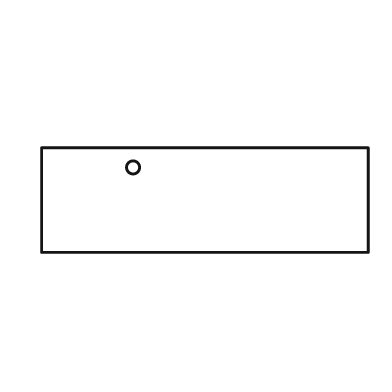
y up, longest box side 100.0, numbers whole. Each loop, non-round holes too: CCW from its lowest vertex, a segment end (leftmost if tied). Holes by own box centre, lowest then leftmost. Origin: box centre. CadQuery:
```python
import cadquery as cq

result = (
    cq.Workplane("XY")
    .moveTo(-50.0, -16.0)
    .lineTo(50.0, -16.0)
    .lineTo(50.0, 16.0)
    .lineTo(-50.0, 16.0)
    .close()
    .moveTo(-22.0, 10.0)
    .circle(2.0)
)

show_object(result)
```